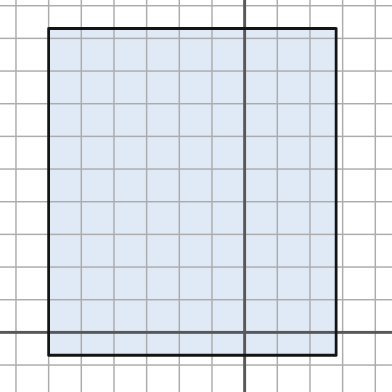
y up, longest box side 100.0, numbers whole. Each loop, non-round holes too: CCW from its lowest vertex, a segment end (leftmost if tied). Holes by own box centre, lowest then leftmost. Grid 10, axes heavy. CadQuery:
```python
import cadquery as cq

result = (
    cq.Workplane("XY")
    .moveTo(-60.0, -7.0)
    .lineTo(28.0, -7.0)
    .lineTo(28.0, 93.0)
    .lineTo(-60.0, 93.0)
    .close()
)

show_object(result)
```